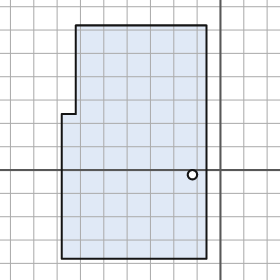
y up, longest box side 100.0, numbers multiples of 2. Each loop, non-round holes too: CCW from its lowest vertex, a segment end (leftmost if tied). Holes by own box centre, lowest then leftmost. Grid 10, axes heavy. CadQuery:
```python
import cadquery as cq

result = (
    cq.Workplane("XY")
    .moveTo(-68.0, -38.0)
    .lineTo(-6.0, -38.0)
    .lineTo(-6.0, 62.0)
    .lineTo(-62.0, 62.0)
    .lineTo(-62.0, 24.0)
    .lineTo(-68.0, 24.0)
    .close()
    .moveTo(-12.0, -2.0)
    .circle(2.0)
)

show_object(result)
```